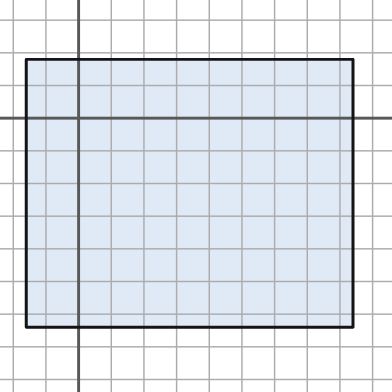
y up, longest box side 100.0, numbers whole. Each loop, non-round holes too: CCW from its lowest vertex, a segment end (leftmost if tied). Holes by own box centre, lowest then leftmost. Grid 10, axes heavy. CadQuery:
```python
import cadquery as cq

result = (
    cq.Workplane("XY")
    .moveTo(-16.0, -64.0)
    .lineTo(84.0, -64.0)
    .lineTo(84.0, 18.0)
    .lineTo(-16.0, 18.0)
    .close()
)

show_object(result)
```